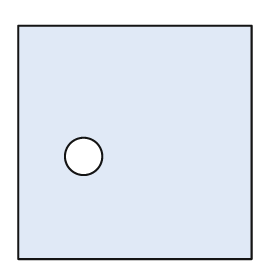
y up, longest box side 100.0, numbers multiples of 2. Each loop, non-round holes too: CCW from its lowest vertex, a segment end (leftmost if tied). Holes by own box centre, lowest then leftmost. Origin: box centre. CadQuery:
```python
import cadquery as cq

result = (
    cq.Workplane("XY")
    .moveTo(-50.0, -50.0)
    .lineTo(50.0, -50.0)
    .lineTo(50.0, 50.0)
    .lineTo(-50.0, 50.0)
    .close()
    .moveTo(-22.0, -6.0)
    .circle(8.0)
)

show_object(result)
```